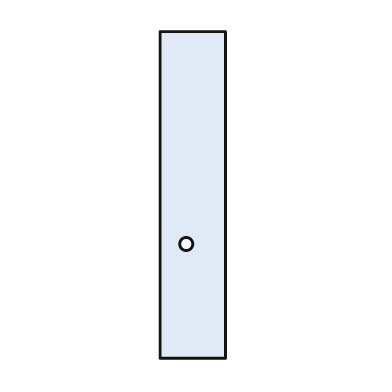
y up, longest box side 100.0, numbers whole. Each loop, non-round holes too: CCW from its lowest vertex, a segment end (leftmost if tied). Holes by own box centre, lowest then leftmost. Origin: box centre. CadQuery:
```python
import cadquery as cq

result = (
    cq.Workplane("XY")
    .moveTo(-10.0, -50.0)
    .lineTo(10.0, -50.0)
    .lineTo(10.0, 50.0)
    .lineTo(-10.0, 50.0)
    .close()
    .moveTo(-2.0, -15.0)
    .circle(2.0)
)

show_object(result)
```